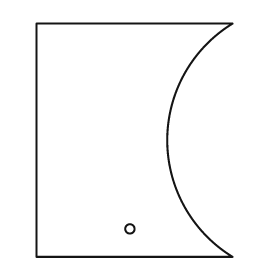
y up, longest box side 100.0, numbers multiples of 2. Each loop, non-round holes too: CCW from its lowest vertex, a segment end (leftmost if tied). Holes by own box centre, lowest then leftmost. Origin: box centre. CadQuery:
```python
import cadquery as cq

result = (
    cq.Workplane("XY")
    .moveTo(-42.0, -50.0)
    .lineTo(42.0, -50.0)
    .threePointArc((14.0, 0.0), (42.0, 50.0))
    .lineTo(-42.0, 50.0)
    .close()
    .moveTo(-2.0, -38.0)
    .circle(2.0)
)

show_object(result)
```